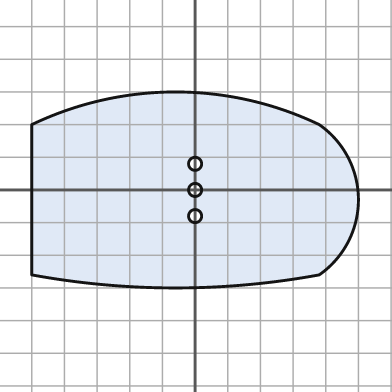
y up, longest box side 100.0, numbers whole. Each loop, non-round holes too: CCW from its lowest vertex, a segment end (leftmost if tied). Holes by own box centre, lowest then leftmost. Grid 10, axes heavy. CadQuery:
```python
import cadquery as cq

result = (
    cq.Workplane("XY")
    .moveTo(-50.0, -26.0)
    .threePointArc((-6.0, -30.0), (38.0, -26.0))
    .threePointArc((50.0, -3.0), (38.0, 20.0))
    .threePointArc((-6.0, 30.0), (-50.0, 20.0))
    .close()
    .moveTo(0.0, -8.0)
    .circle(2.0)
    .moveTo(0.0, 0.0)
    .circle(2.0)
    .moveTo(0.0, 8.0)
    .circle(2.0)
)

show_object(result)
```